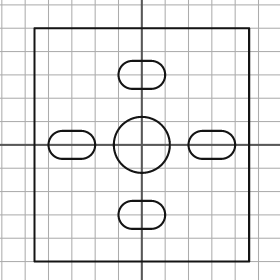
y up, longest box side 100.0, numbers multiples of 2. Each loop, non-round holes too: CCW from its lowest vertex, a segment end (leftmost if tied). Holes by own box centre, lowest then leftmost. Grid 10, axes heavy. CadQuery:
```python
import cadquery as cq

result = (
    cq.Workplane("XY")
    .moveTo(-46.0, -50.0)
    .lineTo(46.0, -50.0)
    .lineTo(46.0, 50.0)
    .lineTo(-46.0, 50.0)
    .close()
    .moveTo(-4.0, -36.0)
    .lineTo(4.0, -36.0)
    .threePointArc((10.0, -30.0), (4.0, -24.0))
    .lineTo(-4.0, -24.0)
    .threePointArc((-10.0, -30.0), (-4.0, -36.0))
    .close()
    .moveTo(-34.0, -6.0)
    .lineTo(-26.0, -6.0)
    .threePointArc((-20.0, 0.0), (-26.0, 6.0))
    .lineTo(-34.0, 6.0)
    .threePointArc((-40.0, 0.0), (-34.0, -6.0))
    .close()
    .moveTo(0.0, 0.0)
    .circle(12.0)
    .moveTo(26.0, -6.0)
    .lineTo(34.0, -6.0)
    .threePointArc((40.0, 0.0), (34.0, 6.0))
    .lineTo(26.0, 6.0)
    .threePointArc((20.0, 0.0), (26.0, -6.0))
    .close()
    .moveTo(-4.0, 24.0)
    .lineTo(4.0, 24.0)
    .threePointArc((10.0, 30.0), (4.0, 36.0))
    .lineTo(-4.0, 36.0)
    .threePointArc((-10.0, 30.0), (-4.0, 24.0))
    .close()
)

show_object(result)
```